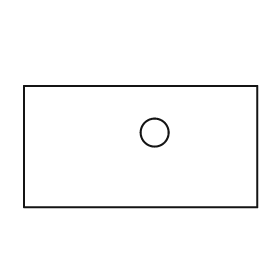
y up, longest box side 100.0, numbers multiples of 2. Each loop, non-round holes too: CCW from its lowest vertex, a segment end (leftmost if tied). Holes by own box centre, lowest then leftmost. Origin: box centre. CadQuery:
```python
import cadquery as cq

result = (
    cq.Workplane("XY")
    .moveTo(-50.0, -26.0)
    .lineTo(50.0, -26.0)
    .lineTo(50.0, 26.0)
    .lineTo(-50.0, 26.0)
    .close()
    .moveTo(6.0, 6.0)
    .circle(6.0)
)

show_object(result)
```